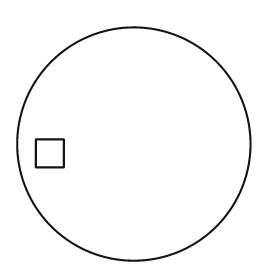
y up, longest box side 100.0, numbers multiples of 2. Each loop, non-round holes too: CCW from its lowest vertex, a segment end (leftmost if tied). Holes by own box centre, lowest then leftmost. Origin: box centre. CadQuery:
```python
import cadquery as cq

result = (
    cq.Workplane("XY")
    .moveTo(0.0, 0.0)
    .circle(50.0)
    .moveTo(-42.0, -10.0)
    .lineTo(-30.0, -10.0)
    .lineTo(-30.0, 2.0)
    .lineTo(-42.0, 2.0)
    .close()
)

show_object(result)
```